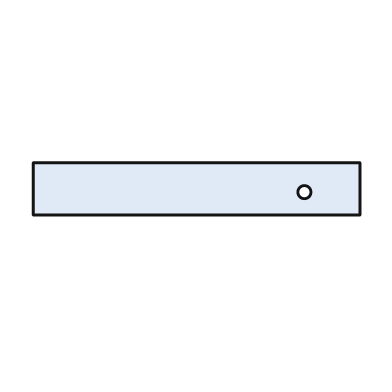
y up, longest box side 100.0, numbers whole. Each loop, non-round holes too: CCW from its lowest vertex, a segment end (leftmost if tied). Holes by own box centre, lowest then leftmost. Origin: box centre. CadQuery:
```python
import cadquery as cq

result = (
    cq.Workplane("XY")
    .moveTo(-50.0, -8.0)
    .lineTo(50.0, -8.0)
    .lineTo(50.0, 8.0)
    .lineTo(-50.0, 8.0)
    .close()
    .moveTo(33.0, -1.0)
    .circle(2.0)
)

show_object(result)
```